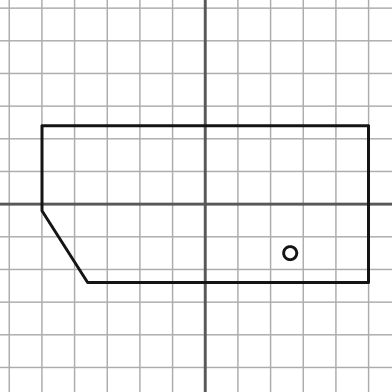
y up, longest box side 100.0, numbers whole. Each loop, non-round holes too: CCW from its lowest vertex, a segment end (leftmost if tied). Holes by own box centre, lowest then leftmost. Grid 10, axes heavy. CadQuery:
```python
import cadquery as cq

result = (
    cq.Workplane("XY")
    .moveTo(-36.0, -24.0)
    .lineTo(50.0, -24.0)
    .lineTo(50.0, 24.0)
    .lineTo(-50.0, 24.0)
    .lineTo(-50.0, -2.0)
    .close()
    .moveTo(26.0, -15.0)
    .circle(2.0)
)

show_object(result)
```